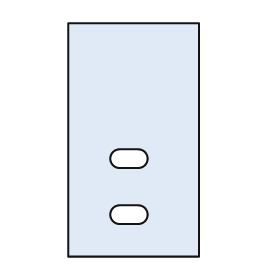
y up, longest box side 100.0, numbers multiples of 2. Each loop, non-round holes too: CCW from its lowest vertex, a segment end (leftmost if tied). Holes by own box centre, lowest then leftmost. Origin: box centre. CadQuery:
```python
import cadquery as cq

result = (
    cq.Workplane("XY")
    .moveTo(-28.0, -50.0)
    .lineTo(28.0, -50.0)
    .lineTo(28.0, 50.0)
    .lineTo(-28.0, 50.0)
    .close()
    .moveTo(-6.0, -36.0)
    .lineTo(2.0, -36.0)
    .threePointArc((6.0, -32.0), (2.0, -28.0))
    .lineTo(-6.0, -28.0)
    .threePointArc((-10.0, -32.0), (-6.0, -36.0))
    .close()
    .moveTo(-6.0, -12.0)
    .lineTo(2.0, -12.0)
    .threePointArc((6.0, -8.0), (2.0, -4.0))
    .lineTo(-6.0, -4.0)
    .threePointArc((-10.0, -8.0), (-6.0, -12.0))
    .close()
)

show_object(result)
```